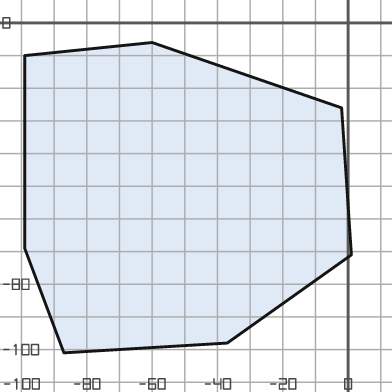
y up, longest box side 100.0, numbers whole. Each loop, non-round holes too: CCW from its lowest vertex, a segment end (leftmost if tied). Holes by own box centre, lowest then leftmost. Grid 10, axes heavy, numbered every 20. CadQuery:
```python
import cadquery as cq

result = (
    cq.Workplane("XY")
    .moveTo(-87.0, -101.0)
    .lineTo(-37.0, -98.0)
    .lineTo(1.0, -71.0)
    .lineTo(-2.0, -26.0)
    .lineTo(-60.0, -6.0)
    .lineTo(-99.0, -10.0)
    .lineTo(-99.0, -69.0)
    .close()
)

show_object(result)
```